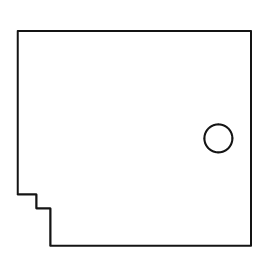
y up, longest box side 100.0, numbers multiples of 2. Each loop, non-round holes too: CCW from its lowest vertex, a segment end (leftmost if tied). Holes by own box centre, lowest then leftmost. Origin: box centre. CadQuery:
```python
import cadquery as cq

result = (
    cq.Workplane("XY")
    .moveTo(-36.0, -46.0)
    .lineTo(50.0, -46.0)
    .lineTo(50.0, 46.0)
    .lineTo(-50.0, 46.0)
    .lineTo(-50.0, -24.0)
    .lineTo(-42.0, -24.0)
    .lineTo(-42.0, -30.0)
    .lineTo(-36.0, -30.0)
    .close()
    .moveTo(36.0, 0.0)
    .circle(6.0)
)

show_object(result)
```